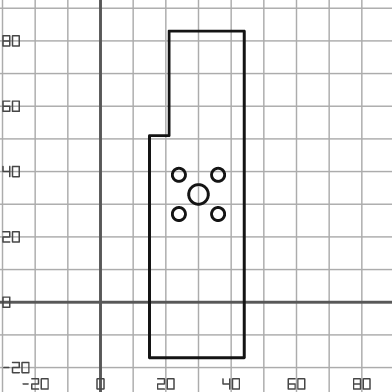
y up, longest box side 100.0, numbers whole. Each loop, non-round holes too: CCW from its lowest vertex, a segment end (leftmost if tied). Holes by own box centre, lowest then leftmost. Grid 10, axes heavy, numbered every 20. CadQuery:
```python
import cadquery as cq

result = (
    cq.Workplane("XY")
    .moveTo(15.0, -17.0)
    .lineTo(44.0, -17.0)
    .lineTo(44.0, 83.0)
    .lineTo(21.0, 83.0)
    .lineTo(21.0, 51.0)
    .lineTo(15.0, 51.0)
    .close()
    .moveTo(24.0, 27.0)
    .circle(2.0)
    .moveTo(36.0, 27.0)
    .circle(2.0)
    .moveTo(30.0, 33.0)
    .circle(3.0)
    .moveTo(24.0, 39.0)
    .circle(2.0)
    .moveTo(36.0, 39.0)
    .circle(2.0)
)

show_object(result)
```